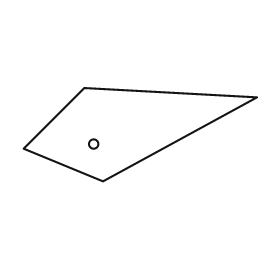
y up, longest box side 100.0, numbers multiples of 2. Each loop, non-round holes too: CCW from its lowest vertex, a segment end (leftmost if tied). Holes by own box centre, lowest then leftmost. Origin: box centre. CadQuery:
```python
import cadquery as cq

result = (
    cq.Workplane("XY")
    .moveTo(-16.0, -20.0)
    .lineTo(50.0, 16.0)
    .lineTo(-24.0, 20.0)
    .lineTo(-50.0, -6.0)
    .close()
    .moveTo(-20.0, -4.0)
    .circle(2.0)
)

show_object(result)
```